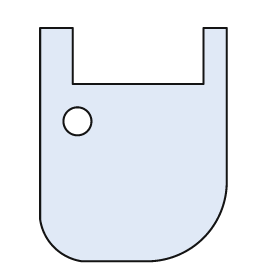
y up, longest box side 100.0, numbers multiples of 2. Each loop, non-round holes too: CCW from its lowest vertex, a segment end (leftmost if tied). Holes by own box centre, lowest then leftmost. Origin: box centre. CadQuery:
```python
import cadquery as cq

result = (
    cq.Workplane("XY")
    .moveTo(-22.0, -50.0)
    .lineTo(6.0, -50.0)
    .threePointArc((30.0, -40.0), (40.0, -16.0))
    .lineTo(40.0, 50.0)
    .lineTo(30.0, 50.0)
    .lineTo(30.0, 26.0)
    .lineTo(-26.0, 26.0)
    .lineTo(-26.0, 50.0)
    .lineTo(-40.0, 50.0)
    .lineTo(-40.0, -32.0)
    .threePointArc((-34.0, -44.0), (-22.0, -50.0))
    .close()
    .moveTo(-24.0, 10.0)
    .circle(6.0)
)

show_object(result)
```